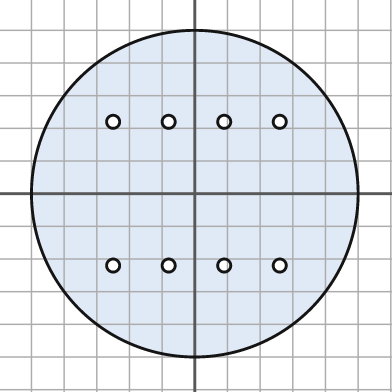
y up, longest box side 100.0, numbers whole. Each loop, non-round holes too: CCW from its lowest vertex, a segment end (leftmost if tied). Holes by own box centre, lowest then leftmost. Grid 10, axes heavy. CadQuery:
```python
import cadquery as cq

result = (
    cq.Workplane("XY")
    .moveTo(0.0, 0.0)
    .circle(50.0)
    .moveTo(-25.0, -22.0)
    .circle(2.0)
    .moveTo(-8.0, -22.0)
    .circle(2.0)
    .moveTo(9.0, -22.0)
    .circle(2.0)
    .moveTo(26.0, -22.0)
    .circle(2.0)
    .moveTo(-25.0, 22.0)
    .circle(2.0)
    .moveTo(-8.0, 22.0)
    .circle(2.0)
    .moveTo(9.0, 22.0)
    .circle(2.0)
    .moveTo(26.0, 22.0)
    .circle(2.0)
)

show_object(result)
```